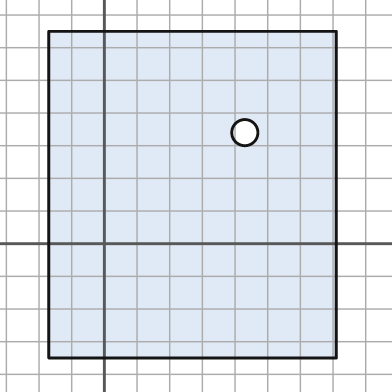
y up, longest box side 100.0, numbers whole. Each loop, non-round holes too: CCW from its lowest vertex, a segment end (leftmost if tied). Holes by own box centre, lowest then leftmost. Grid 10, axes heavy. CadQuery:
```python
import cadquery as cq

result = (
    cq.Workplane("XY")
    .moveTo(-17.0, -35.0)
    .lineTo(71.0, -35.0)
    .lineTo(71.0, 65.0)
    .lineTo(-17.0, 65.0)
    .close()
    .moveTo(43.0, 34.0)
    .circle(4.0)
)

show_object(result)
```